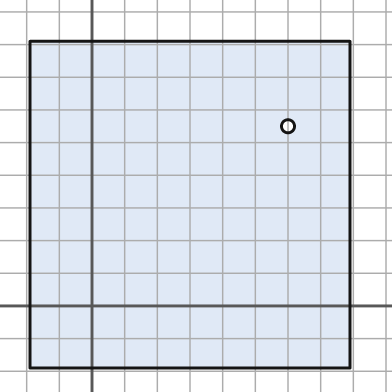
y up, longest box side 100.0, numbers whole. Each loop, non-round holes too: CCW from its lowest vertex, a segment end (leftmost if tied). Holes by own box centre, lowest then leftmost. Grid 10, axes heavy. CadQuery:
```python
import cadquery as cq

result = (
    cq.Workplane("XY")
    .moveTo(-19.0, -19.0)
    .lineTo(79.0, -19.0)
    .lineTo(79.0, 81.0)
    .lineTo(-19.0, 81.0)
    .close()
    .moveTo(60.0, 55.0)
    .circle(2.0)
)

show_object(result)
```